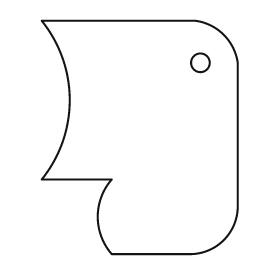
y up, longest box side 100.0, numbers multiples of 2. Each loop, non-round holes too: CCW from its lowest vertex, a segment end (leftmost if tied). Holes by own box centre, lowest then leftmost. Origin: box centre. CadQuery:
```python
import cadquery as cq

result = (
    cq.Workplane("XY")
    .moveTo(-12.0, -50.0)
    .lineTo(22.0, -50.0)
    .threePointArc((36.0, -44.0), (42.0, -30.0))
    .lineTo(42.0, 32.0)
    .threePointArc((36.0, 44.0), (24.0, 50.0))
    .lineTo(-42.0, 50.0)
    .threePointArc((-30.0, 16.0), (-42.0, -18.0))
    .lineTo(-12.0, -18.0)
    .threePointArc((-18.0, -34.0), (-12.0, -50.0))
    .close()
    .moveTo(26.0, 32.0)
    .circle(4.0)
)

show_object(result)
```